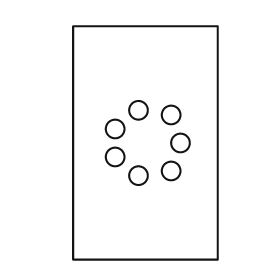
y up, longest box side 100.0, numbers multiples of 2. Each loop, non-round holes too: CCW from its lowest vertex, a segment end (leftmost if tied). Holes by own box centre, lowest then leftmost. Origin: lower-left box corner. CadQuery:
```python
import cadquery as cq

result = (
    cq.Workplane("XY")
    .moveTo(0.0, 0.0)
    .lineTo(62.0, 0.0)
    .lineTo(62.0, 100.0)
    .lineTo(0.0, 100.0)
    .close()
    .moveTo(28.0, 36.0)
    .circle(4.0)
    .moveTo(42.0, 38.0)
    .circle(4.0)
    .moveTo(18.0, 44.0)
    .circle(4.0)
    .moveTo(46.0, 50.0)
    .circle(4.0)
    .moveTo(18.0, 56.0)
    .circle(4.0)
    .moveTo(42.0, 62.0)
    .circle(4.0)
    .moveTo(28.0, 64.0)
    .circle(4.0)
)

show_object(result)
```